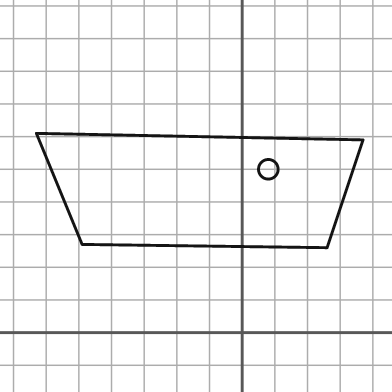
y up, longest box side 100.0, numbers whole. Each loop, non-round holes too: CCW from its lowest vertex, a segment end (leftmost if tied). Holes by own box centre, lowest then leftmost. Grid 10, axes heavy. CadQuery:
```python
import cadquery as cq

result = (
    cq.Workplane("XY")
    .moveTo(26.0, 26.0)
    .lineTo(37.0, 59.0)
    .lineTo(-63.0, 61.0)
    .lineTo(-49.0, 27.0)
    .close()
    .moveTo(8.0, 50.0)
    .circle(3.0)
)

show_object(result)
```